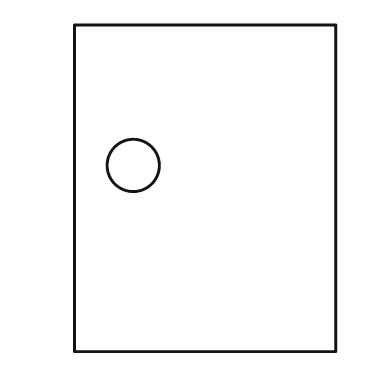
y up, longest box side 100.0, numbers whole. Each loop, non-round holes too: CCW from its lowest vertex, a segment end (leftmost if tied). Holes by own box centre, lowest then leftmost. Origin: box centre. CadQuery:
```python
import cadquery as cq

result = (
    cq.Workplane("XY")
    .moveTo(-40.0, -50.0)
    .lineTo(40.0, -50.0)
    .lineTo(40.0, 50.0)
    .lineTo(-40.0, 50.0)
    .close()
    .moveTo(-22.0, 7.0)
    .circle(8.0)
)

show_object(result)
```